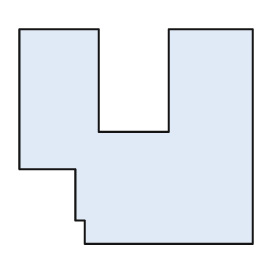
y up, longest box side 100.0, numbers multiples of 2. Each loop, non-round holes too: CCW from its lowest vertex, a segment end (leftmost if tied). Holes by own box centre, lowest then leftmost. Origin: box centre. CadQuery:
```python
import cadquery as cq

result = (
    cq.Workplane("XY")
    .moveTo(-22.0, -46.0)
    .lineTo(50.0, -46.0)
    .lineTo(50.0, 46.0)
    .lineTo(14.0, 46.0)
    .lineTo(14.0, 2.0)
    .lineTo(-16.0, 2.0)
    .lineTo(-16.0, 46.0)
    .lineTo(-50.0, 46.0)
    .lineTo(-50.0, -14.0)
    .lineTo(-26.0, -14.0)
    .lineTo(-26.0, -36.0)
    .lineTo(-22.0, -36.0)
    .close()
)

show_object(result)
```